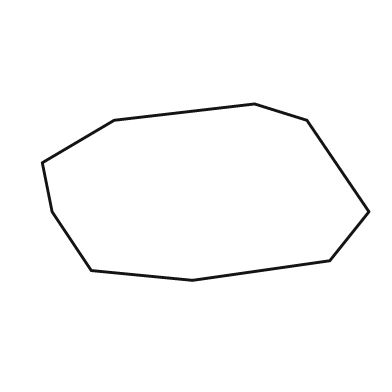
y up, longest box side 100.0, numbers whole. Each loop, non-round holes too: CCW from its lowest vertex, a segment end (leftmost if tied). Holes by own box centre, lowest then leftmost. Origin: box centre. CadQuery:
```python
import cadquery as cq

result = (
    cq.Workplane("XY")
    .moveTo(-4.0, -27.0)
    .lineTo(38.0, -21.0)
    .lineTo(50.0, -6.0)
    .lineTo(31.0, 22.0)
    .lineTo(15.0, 27.0)
    .lineTo(-28.0, 22.0)
    .lineTo(-50.0, 9.0)
    .lineTo(-47.0, -6.0)
    .lineTo(-35.0, -24.0)
    .close()
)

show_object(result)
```